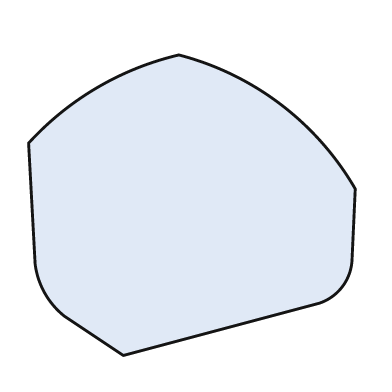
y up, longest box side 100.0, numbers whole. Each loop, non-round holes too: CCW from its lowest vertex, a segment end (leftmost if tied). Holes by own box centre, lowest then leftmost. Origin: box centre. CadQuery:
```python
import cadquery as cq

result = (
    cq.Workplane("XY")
    .moveTo(-21.0, -46.0)
    .lineTo(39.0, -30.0)
    .threePointArc((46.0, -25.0), (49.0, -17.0))
    .lineTo(50.0, 5.0)
    .threePointArc((27.0, 31.0), (-4.0, 46.0))
    .threePointArc((-29.0, 36.0), (-50.0, 19.0))
    .lineTo(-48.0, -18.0)
    .threePointArc((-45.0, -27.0), (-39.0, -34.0))
    .close()
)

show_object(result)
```